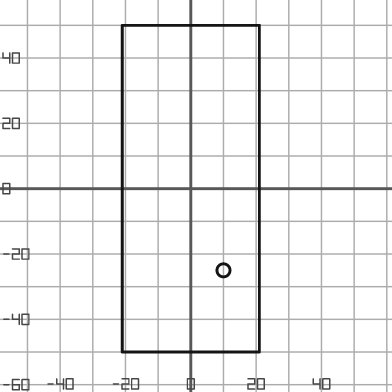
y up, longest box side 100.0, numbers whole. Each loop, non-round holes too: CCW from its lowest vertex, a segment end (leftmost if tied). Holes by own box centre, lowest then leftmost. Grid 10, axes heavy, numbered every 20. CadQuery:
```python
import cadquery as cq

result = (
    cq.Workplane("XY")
    .moveTo(-21.0, -50.0)
    .lineTo(21.0, -50.0)
    .lineTo(21.0, 50.0)
    .lineTo(-21.0, 50.0)
    .close()
    .moveTo(10.0, -25.0)
    .circle(2.0)
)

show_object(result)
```